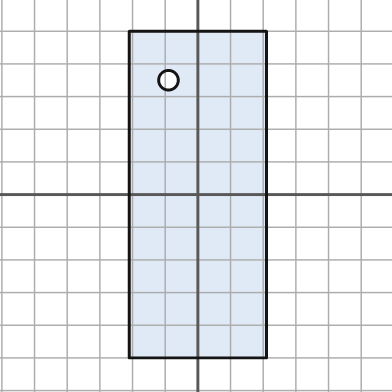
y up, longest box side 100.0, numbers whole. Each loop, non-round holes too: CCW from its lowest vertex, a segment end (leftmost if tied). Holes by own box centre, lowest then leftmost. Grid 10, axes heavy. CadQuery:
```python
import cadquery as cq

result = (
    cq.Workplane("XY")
    .moveTo(-21.0, -50.0)
    .lineTo(21.0, -50.0)
    .lineTo(21.0, 50.0)
    .lineTo(-21.0, 50.0)
    .close()
    .moveTo(-9.0, 35.0)
    .circle(3.0)
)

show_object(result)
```